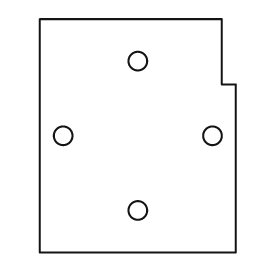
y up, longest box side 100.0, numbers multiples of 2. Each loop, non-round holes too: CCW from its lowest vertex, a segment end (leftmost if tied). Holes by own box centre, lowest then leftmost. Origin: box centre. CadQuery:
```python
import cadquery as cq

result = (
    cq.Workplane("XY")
    .moveTo(-42.0, -50.0)
    .lineTo(42.0, -50.0)
    .lineTo(42.0, 22.0)
    .lineTo(36.0, 22.0)
    .lineTo(36.0, 50.0)
    .lineTo(-42.0, 50.0)
    .close()
    .moveTo(0.0, -32.0)
    .circle(4.0)
    .moveTo(-32.0, 0.0)
    .circle(4.0)
    .moveTo(32.0, 0.0)
    .circle(4.0)
    .moveTo(0.0, 32.0)
    .circle(4.0)
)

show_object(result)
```